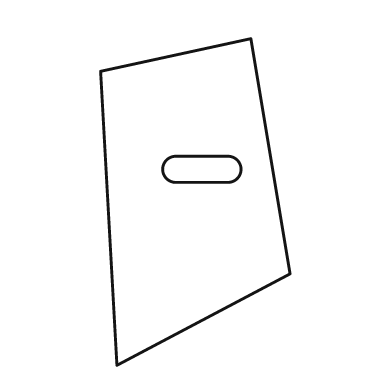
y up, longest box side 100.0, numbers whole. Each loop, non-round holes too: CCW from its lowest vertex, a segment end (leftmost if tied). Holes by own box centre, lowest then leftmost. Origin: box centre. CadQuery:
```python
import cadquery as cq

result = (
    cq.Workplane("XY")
    .moveTo(-24.0, -50.0)
    .lineTo(29.0, -22.0)
    .lineTo(17.0, 50.0)
    .lineTo(-29.0, 40.0)
    .close()
    .moveTo(-6.0, 6.0)
    .lineTo(10.0, 6.0)
    .threePointArc((14.0, 10.0), (10.0, 14.0))
    .lineTo(-6.0, 14.0)
    .threePointArc((-10.0, 10.0), (-6.0, 6.0))
    .close()
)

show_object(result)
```